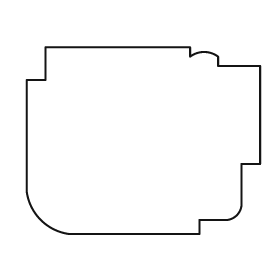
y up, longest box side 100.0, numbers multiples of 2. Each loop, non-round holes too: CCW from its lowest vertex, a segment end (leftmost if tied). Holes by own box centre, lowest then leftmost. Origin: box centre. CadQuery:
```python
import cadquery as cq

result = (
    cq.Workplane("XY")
    .moveTo(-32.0, -40.0)
    .lineTo(24.0, -40.0)
    .lineTo(24.0, -34.0)
    .lineTo(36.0, -34.0)
    .threePointArc((40.0, -32.0), (42.0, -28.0))
    .lineTo(42.0, -10.0)
    .lineTo(50.0, -10.0)
    .lineTo(50.0, 32.0)
    .lineTo(32.0, 32.0)
    .lineTo(32.0, 36.0)
    .threePointArc((26.0, 38.0), (20.0, 36.0))
    .lineTo(20.0, 40.0)
    .lineTo(-42.0, 40.0)
    .lineTo(-42.0, 26.0)
    .lineTo(-50.0, 26.0)
    .lineTo(-50.0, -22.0)
    .threePointArc((-44.0, -34.0), (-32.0, -40.0))
    .close()
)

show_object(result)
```